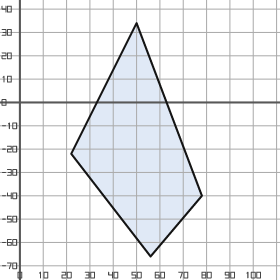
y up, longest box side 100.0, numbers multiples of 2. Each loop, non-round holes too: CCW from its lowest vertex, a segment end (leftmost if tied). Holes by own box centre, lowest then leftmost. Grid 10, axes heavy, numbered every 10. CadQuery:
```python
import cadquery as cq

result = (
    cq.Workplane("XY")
    .moveTo(56.0, -66.0)
    .lineTo(78.0, -40.0)
    .lineTo(50.0, 34.0)
    .lineTo(22.0, -22.0)
    .close()
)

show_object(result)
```